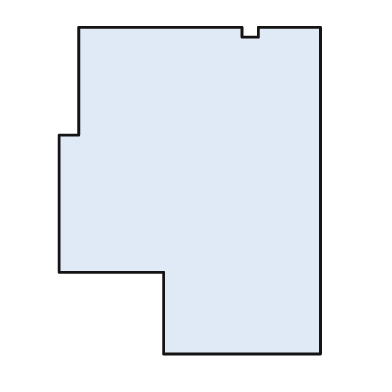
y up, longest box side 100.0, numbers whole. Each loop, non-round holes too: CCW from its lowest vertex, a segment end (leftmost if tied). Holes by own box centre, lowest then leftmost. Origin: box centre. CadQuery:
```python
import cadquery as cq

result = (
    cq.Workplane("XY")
    .moveTo(-8.0, -50.0)
    .lineTo(40.0, -50.0)
    .lineTo(40.0, 50.0)
    .lineTo(21.0, 50.0)
    .lineTo(21.0, 47.0)
    .lineTo(16.0, 47.0)
    .lineTo(16.0, 50.0)
    .lineTo(-34.0, 50.0)
    .lineTo(-34.0, 17.0)
    .lineTo(-40.0, 17.0)
    .lineTo(-40.0, -25.0)
    .lineTo(-8.0, -25.0)
    .close()
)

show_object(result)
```